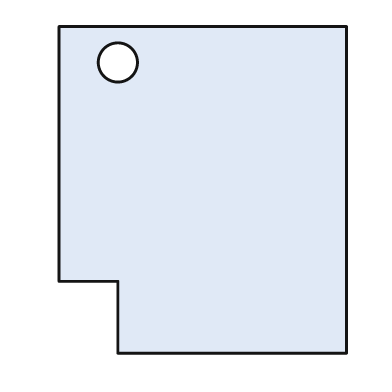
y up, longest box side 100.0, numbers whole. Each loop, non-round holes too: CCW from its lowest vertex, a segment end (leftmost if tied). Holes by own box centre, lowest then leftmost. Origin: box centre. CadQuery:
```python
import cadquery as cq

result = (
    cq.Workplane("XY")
    .moveTo(-26.0, -50.0)
    .lineTo(44.0, -50.0)
    .lineTo(44.0, 50.0)
    .lineTo(-44.0, 50.0)
    .lineTo(-44.0, -28.0)
    .lineTo(-26.0, -28.0)
    .close()
    .moveTo(-26.0, 39.0)
    .circle(6.0)
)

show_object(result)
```